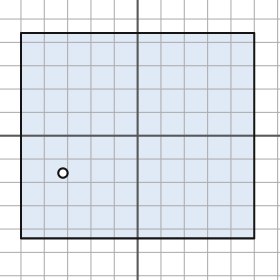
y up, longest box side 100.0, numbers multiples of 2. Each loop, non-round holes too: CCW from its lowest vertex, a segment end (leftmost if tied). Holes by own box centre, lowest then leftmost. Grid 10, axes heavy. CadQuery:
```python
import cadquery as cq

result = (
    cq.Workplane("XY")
    .moveTo(-50.0, -44.0)
    .lineTo(50.0, -44.0)
    .lineTo(50.0, 44.0)
    .lineTo(-50.0, 44.0)
    .close()
    .moveTo(-32.0, -16.0)
    .circle(2.0)
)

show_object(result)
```